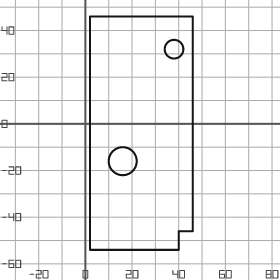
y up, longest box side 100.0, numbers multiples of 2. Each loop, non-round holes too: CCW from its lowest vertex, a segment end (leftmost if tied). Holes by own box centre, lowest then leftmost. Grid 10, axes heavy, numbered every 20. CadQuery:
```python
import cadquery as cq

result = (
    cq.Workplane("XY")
    .moveTo(2.0, -54.0)
    .lineTo(40.0, -54.0)
    .lineTo(40.0, -46.0)
    .lineTo(46.0, -46.0)
    .lineTo(46.0, 46.0)
    .lineTo(2.0, 46.0)
    .close()
    .moveTo(16.0, -16.0)
    .circle(6.0)
    .moveTo(38.0, 32.0)
    .circle(4.0)
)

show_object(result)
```